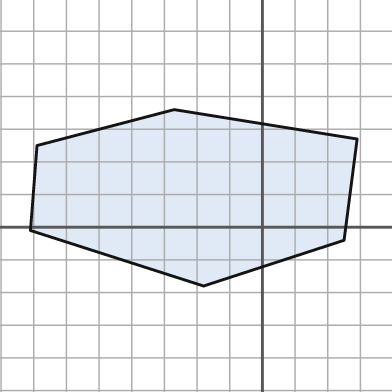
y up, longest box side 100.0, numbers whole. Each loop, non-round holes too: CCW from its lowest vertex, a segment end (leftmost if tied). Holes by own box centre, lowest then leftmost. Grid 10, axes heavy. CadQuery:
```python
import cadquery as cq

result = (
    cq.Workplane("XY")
    .moveTo(-18.0, -18.0)
    .lineTo(25.0, -4.0)
    .lineTo(29.0, 27.0)
    .lineTo(-27.0, 36.0)
    .lineTo(-69.0, 25.0)
    .lineTo(-71.0, -1.0)
    .close()
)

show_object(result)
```